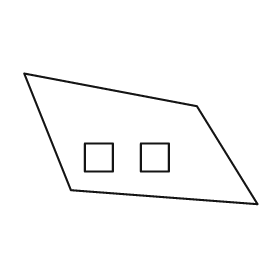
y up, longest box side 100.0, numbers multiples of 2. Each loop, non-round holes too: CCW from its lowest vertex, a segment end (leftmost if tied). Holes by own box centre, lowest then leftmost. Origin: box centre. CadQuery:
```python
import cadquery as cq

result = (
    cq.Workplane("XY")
    .moveTo(50.0, -28.0)
    .lineTo(24.0, 14.0)
    .lineTo(-50.0, 28.0)
    .lineTo(-30.0, -22.0)
    .close()
    .moveTo(-24.0, -14.0)
    .lineTo(-12.0, -14.0)
    .lineTo(-12.0, -2.0)
    .lineTo(-24.0, -2.0)
    .close()
    .moveTo(0.0, -14.0)
    .lineTo(12.0, -14.0)
    .lineTo(12.0, -2.0)
    .lineTo(0.0, -2.0)
    .close()
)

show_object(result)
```